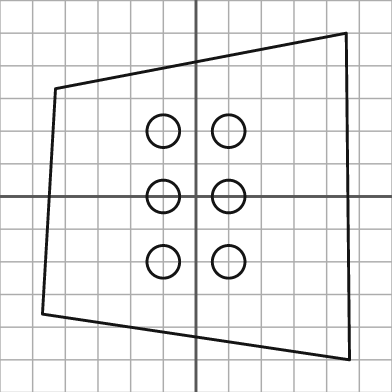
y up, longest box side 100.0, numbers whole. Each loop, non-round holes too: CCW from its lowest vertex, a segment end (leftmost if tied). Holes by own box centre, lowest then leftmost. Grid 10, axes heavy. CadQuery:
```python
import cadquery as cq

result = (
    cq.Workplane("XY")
    .moveTo(47.0, -50.0)
    .lineTo(46.0, 50.0)
    .lineTo(-43.0, 33.0)
    .lineTo(-47.0, -36.0)
    .close()
    .moveTo(-10.0, -20.0)
    .circle(5.0)
    .moveTo(10.0, -20.0)
    .circle(5.0)
    .moveTo(-10.0, 0.0)
    .circle(5.0)
    .moveTo(10.0, 0.0)
    .circle(5.0)
    .moveTo(-10.0, 20.0)
    .circle(5.0)
    .moveTo(10.0, 20.0)
    .circle(5.0)
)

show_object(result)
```